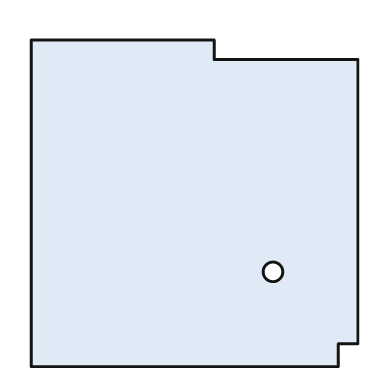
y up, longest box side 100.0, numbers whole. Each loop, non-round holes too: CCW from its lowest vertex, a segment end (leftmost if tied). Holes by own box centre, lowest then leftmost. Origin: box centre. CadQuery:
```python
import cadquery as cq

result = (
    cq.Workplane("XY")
    .moveTo(-50.0, -50.0)
    .lineTo(44.0, -50.0)
    .lineTo(44.0, -43.0)
    .lineTo(50.0, -43.0)
    .lineTo(50.0, 44.0)
    .lineTo(6.0, 44.0)
    .lineTo(6.0, 50.0)
    .lineTo(-50.0, 50.0)
    .close()
    .moveTo(24.0, -21.0)
    .circle(3.0)
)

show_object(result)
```